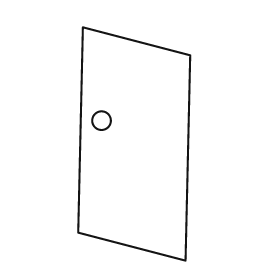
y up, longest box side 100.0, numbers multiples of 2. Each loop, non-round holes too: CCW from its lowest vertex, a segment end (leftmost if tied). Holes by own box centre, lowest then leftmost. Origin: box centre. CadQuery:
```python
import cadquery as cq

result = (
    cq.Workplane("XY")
    .moveTo(22.0, -50.0)
    .lineTo(24.0, 38.0)
    .lineTo(-22.0, 50.0)
    .lineTo(-24.0, -38.0)
    .close()
    .moveTo(-14.0, 10.0)
    .circle(4.0)
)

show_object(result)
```